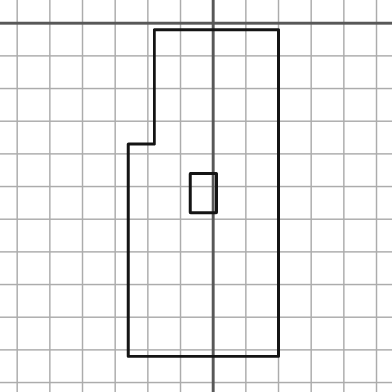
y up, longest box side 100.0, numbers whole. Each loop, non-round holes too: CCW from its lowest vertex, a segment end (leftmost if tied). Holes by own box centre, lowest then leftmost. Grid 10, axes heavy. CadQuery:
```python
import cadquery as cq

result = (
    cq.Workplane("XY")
    .moveTo(-26.0, -102.0)
    .lineTo(20.0, -102.0)
    .lineTo(20.0, -2.0)
    .lineTo(-18.0, -2.0)
    .lineTo(-18.0, -37.0)
    .lineTo(-26.0, -37.0)
    .close()
    .moveTo(-7.0, -58.0)
    .lineTo(1.0, -58.0)
    .lineTo(1.0, -46.0)
    .lineTo(-7.0, -46.0)
    .close()
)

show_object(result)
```